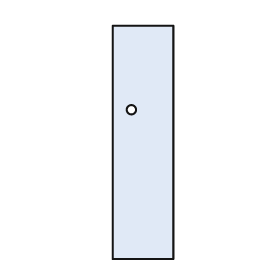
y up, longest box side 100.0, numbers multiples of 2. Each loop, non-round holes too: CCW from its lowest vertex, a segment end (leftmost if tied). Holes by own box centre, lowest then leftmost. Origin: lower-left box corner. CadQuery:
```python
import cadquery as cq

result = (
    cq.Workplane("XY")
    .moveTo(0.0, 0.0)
    .lineTo(26.0, 0.0)
    .lineTo(26.0, 100.0)
    .lineTo(0.0, 100.0)
    .close()
    .moveTo(8.0, 64.0)
    .circle(2.0)
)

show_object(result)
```